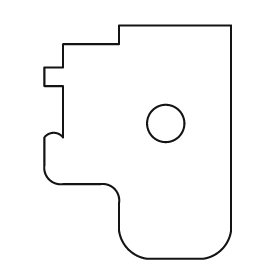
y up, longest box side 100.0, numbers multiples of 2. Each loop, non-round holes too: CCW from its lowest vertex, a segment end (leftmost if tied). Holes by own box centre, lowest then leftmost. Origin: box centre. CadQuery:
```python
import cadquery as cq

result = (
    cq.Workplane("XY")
    .moveTo(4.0, -50.0)
    .lineTo(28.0, -50.0)
    .threePointArc((36.0, -46.0), (40.0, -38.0))
    .lineTo(40.0, 50.0)
    .lineTo(-8.0, 50.0)
    .lineTo(-8.0, 42.0)
    .lineTo(-32.0, 42.0)
    .lineTo(-32.0, 32.0)
    .lineTo(-40.0, 32.0)
    .lineTo(-40.0, 24.0)
    .lineTo(-32.0, 24.0)
    .lineTo(-32.0, 2.0)
    .threePointArc((-36.0, 4.0), (-40.0, 2.0))
    .lineTo(-40.0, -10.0)
    .threePointArc((-38.0, -16.0), (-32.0, -18.0))
    .lineTo(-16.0, -18.0)
    .threePointArc((-10.0, -20.0), (-8.0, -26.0))
    .lineTo(-8.0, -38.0)
    .threePointArc((-4.0, -46.0), (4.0, -50.0))
    .close()
    .moveTo(12.0, 8.0)
    .circle(8.0)
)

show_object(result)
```